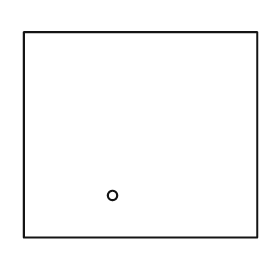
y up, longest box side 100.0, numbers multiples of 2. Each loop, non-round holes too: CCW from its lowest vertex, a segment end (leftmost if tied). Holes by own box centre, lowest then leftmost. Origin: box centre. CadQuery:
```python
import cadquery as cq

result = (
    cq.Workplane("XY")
    .moveTo(-50.0, -44.0)
    .lineTo(50.0, -44.0)
    .lineTo(50.0, 44.0)
    .lineTo(-50.0, 44.0)
    .close()
    .moveTo(-12.0, -26.0)
    .circle(2.0)
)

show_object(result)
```